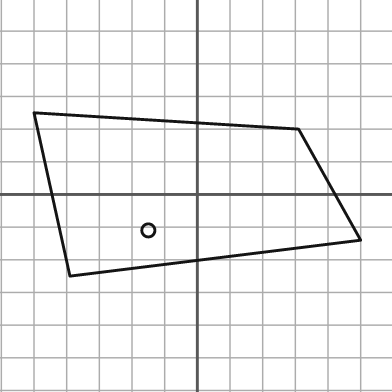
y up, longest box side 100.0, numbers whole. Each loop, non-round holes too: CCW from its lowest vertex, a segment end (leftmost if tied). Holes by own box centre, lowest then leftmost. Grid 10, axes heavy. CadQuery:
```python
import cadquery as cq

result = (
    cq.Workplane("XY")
    .moveTo(-39.0, -25.0)
    .lineTo(50.0, -14.0)
    .lineTo(31.0, 20.0)
    .lineTo(-50.0, 25.0)
    .close()
    .moveTo(-15.0, -11.0)
    .circle(2.0)
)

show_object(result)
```